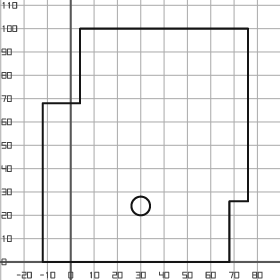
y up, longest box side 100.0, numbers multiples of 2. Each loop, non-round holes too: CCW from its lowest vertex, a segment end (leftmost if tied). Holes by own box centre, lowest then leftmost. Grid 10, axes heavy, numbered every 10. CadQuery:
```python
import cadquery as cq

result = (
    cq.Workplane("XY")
    .moveTo(-12.0, 0.0)
    .lineTo(68.0, 0.0)
    .lineTo(68.0, 26.0)
    .lineTo(76.0, 26.0)
    .lineTo(76.0, 100.0)
    .lineTo(4.0, 100.0)
    .lineTo(4.0, 68.0)
    .lineTo(-12.0, 68.0)
    .close()
    .moveTo(30.0, 24.0)
    .circle(4.0)
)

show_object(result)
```